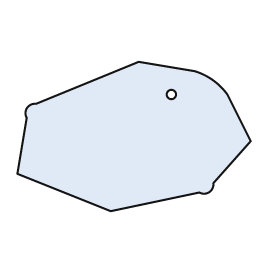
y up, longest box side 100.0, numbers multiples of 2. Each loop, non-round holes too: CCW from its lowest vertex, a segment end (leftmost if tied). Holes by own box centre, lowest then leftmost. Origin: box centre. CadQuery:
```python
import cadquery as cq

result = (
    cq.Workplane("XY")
    .moveTo(-10.0, -32.0)
    .lineTo(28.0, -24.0)
    .threePointArc((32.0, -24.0), (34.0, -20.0))
    .lineTo(50.0, -2.0)
    .lineTo(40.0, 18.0)
    .threePointArc((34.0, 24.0), (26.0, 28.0))
    .lineTo(2.0, 32.0)
    .lineTo(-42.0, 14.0)
    .threePointArc((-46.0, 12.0), (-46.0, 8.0))
    .lineTo(-50.0, -16.0)
    .close()
    .moveTo(16.0, 18.0)
    .circle(2.0)
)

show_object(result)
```